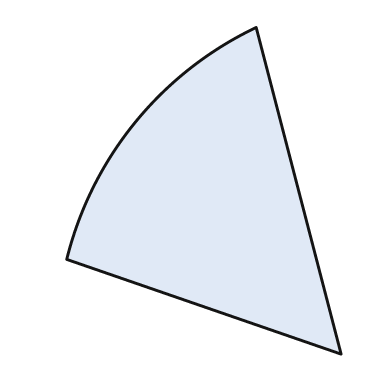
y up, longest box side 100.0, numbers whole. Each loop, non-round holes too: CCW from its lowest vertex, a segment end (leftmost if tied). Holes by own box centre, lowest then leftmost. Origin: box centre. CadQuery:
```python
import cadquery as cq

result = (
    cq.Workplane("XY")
    .moveTo(42.0, -50.0)
    .lineTo(16.0, 50.0)
    .threePointArc((-21.0, 21.0), (-42.0, -21.0))
    .close()
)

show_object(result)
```